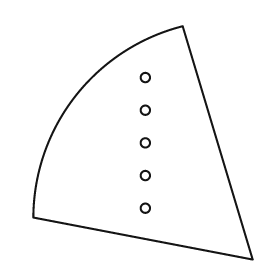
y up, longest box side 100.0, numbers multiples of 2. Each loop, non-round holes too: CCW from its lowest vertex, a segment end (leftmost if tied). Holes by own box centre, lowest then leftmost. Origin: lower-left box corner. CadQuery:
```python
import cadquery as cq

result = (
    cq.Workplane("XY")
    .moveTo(94.0, 0.0)
    .lineTo(64.0, 100.0)
    .threePointArc((18.0, 70.0), (0.0, 18.0))
    .close()
    .moveTo(48.0, 22.0)
    .circle(2.0)
    .moveTo(48.0, 36.0)
    .circle(2.0)
    .moveTo(48.0, 50.0)
    .circle(2.0)
    .moveTo(48.0, 64.0)
    .circle(2.0)
    .moveTo(48.0, 78.0)
    .circle(2.0)
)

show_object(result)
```